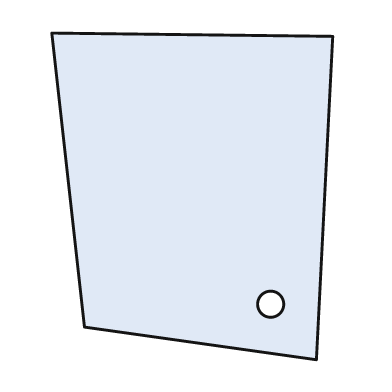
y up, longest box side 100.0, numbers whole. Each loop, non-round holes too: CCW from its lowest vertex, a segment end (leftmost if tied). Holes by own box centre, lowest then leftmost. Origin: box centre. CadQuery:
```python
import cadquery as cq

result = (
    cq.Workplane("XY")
    .moveTo(38.0, -50.0)
    .lineTo(43.0, 49.0)
    .lineTo(-43.0, 50.0)
    .lineTo(-33.0, -40.0)
    .close()
    .moveTo(24.0, -33.0)
    .circle(4.0)
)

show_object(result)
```